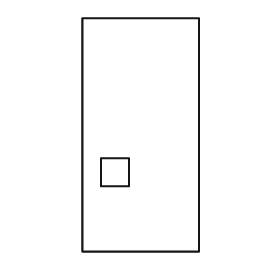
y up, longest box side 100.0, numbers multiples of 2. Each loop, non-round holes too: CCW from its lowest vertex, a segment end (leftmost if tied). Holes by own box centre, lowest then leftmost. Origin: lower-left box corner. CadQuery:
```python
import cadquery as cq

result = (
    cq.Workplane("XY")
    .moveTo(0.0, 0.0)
    .lineTo(50.0, 0.0)
    .lineTo(50.0, 100.0)
    .lineTo(0.0, 100.0)
    .close()
    .moveTo(8.0, 28.0)
    .lineTo(20.0, 28.0)
    .lineTo(20.0, 40.0)
    .lineTo(8.0, 40.0)
    .close()
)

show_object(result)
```